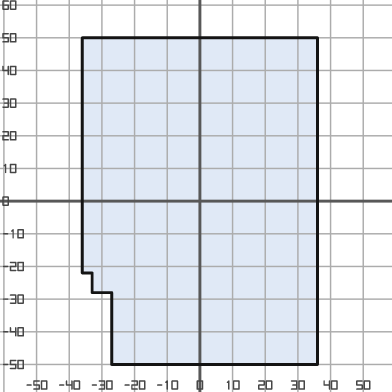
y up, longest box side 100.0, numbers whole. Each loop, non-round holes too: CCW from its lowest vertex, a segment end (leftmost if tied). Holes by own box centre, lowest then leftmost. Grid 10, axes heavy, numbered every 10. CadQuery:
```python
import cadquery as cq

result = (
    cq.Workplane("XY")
    .moveTo(-27.0, -50.0)
    .lineTo(36.0, -50.0)
    .lineTo(36.0, 50.0)
    .lineTo(-36.0, 50.0)
    .lineTo(-36.0, -22.0)
    .lineTo(-33.0, -22.0)
    .lineTo(-33.0, -28.0)
    .lineTo(-27.0, -28.0)
    .close()
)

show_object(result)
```